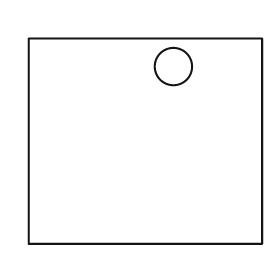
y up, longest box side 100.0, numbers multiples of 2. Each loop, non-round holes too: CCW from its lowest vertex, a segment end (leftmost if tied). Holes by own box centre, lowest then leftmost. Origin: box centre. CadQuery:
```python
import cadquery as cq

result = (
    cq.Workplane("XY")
    .moveTo(-50.0, -44.0)
    .lineTo(50.0, -44.0)
    .lineTo(50.0, 44.0)
    .lineTo(-50.0, 44.0)
    .close()
    .moveTo(12.0, 32.0)
    .circle(8.0)
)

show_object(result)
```